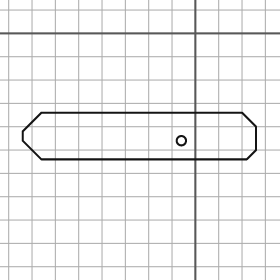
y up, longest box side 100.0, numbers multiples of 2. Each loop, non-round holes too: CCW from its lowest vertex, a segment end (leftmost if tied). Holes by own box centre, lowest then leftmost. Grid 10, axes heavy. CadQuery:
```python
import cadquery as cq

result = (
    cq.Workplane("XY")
    .moveTo(-66.0, -54.0)
    .lineTo(22.0, -54.0)
    .lineTo(26.0, -50.0)
    .lineTo(26.0, -40.0)
    .lineTo(20.0, -34.0)
    .lineTo(-66.0, -34.0)
    .lineTo(-74.0, -42.0)
    .lineTo(-74.0, -46.0)
    .close()
    .moveTo(-6.0, -46.0)
    .circle(2.0)
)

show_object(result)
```